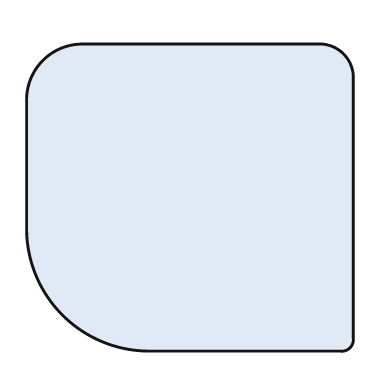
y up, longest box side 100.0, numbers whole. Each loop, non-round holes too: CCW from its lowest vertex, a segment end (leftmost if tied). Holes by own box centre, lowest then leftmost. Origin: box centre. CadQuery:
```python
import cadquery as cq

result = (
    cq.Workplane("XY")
    .moveTo(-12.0, -47.0)
    .lineTo(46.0, -47.0)
    .threePointArc((49.0, -46.0), (50.0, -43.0))
    .lineTo(50.0, 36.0)
    .threePointArc((47.0, 44.0), (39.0, 47.0))
    .lineTo(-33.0, 47.0)
    .threePointArc((-45.0, 42.0), (-50.0, 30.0))
    .lineTo(-50.0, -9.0)
    .threePointArc((-39.0, -36.0), (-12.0, -47.0))
    .close()
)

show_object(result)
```